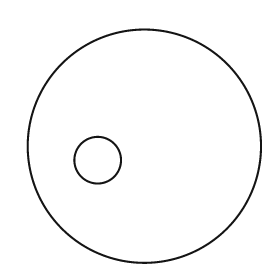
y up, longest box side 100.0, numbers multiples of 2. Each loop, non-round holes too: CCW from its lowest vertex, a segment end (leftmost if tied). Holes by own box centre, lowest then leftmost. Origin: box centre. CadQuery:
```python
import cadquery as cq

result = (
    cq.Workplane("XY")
    .moveTo(0.0, 0.0)
    .circle(50.0)
    .moveTo(-20.0, -6.0)
    .circle(10.0)
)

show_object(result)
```